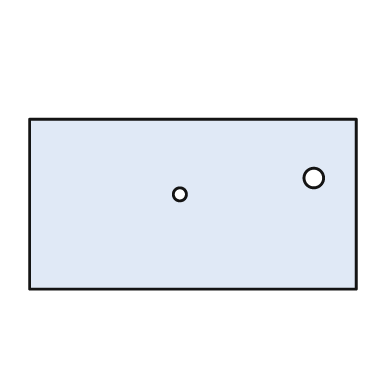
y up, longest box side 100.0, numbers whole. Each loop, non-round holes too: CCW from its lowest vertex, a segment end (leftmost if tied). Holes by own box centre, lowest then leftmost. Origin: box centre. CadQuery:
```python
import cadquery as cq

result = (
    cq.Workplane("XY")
    .moveTo(-50.0, -26.0)
    .lineTo(50.0, -26.0)
    .lineTo(50.0, 26.0)
    .lineTo(-50.0, 26.0)
    .close()
    .moveTo(-4.0, 3.0)
    .circle(2.0)
    .moveTo(37.0, 8.0)
    .circle(3.0)
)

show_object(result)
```